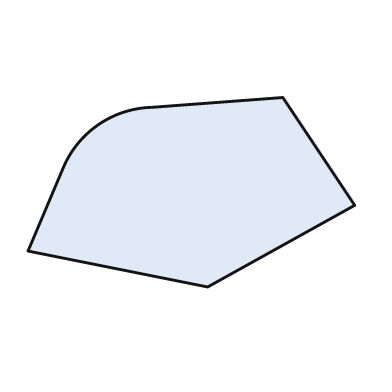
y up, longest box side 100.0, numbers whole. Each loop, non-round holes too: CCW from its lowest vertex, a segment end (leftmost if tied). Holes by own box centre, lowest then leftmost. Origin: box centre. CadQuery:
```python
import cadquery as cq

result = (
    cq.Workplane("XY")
    .moveTo(5.0, -29.0)
    .lineTo(50.0, -4.0)
    .lineTo(28.0, 29.0)
    .lineTo(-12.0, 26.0)
    .threePointArc((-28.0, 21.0), (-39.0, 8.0))
    .lineTo(-50.0, -18.0)
    .close()
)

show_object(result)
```